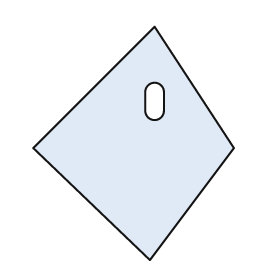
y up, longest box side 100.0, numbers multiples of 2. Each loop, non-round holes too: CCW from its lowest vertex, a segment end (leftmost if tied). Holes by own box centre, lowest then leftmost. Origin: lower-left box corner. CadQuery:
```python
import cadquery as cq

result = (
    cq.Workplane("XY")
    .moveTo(50.0, 0.0)
    .lineTo(86.0, 48.0)
    .lineTo(52.0, 100.0)
    .lineTo(0.0, 48.0)
    .close()
    .moveTo(48.0, 64.0)
    .threePointArc((52.0, 60.0), (56.0, 64.0))
    .lineTo(56.0, 72.0)
    .threePointArc((52.0, 76.0), (48.0, 72.0))
    .close()
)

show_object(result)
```